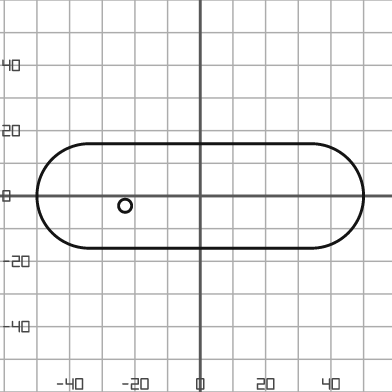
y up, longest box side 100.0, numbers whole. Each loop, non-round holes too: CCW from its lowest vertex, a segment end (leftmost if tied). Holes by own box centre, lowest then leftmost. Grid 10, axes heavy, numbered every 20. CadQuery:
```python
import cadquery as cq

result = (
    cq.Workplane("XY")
    .moveTo(-34.0, -16.0)
    .lineTo(34.0, -16.0)
    .threePointArc((50.0, 0.0), (34.0, 16.0))
    .lineTo(-34.0, 16.0)
    .threePointArc((-50.0, 0.0), (-34.0, -16.0))
    .close()
    .moveTo(-23.0, -3.0)
    .circle(2.0)
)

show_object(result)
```